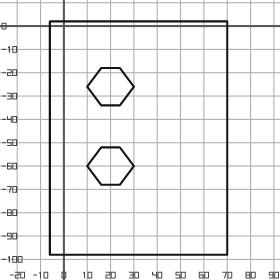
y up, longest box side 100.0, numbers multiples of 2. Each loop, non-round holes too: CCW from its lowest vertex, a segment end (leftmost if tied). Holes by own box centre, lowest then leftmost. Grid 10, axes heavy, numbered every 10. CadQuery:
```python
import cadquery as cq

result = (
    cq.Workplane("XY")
    .moveTo(-6.0, -98.0)
    .lineTo(70.0, -98.0)
    .lineTo(70.0, 2.0)
    .lineTo(-6.0, 2.0)
    .close()
    .moveTo(16.0, -68.0)
    .lineTo(24.0, -68.0)
    .lineTo(30.0, -60.0)
    .lineTo(24.0, -52.0)
    .lineTo(16.0, -52.0)
    .lineTo(10.0, -60.0)
    .close()
    .moveTo(16.0, -34.0)
    .lineTo(24.0, -34.0)
    .lineTo(30.0, -26.0)
    .lineTo(24.0, -18.0)
    .lineTo(16.0, -18.0)
    .lineTo(10.0, -26.0)
    .close()
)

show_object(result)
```